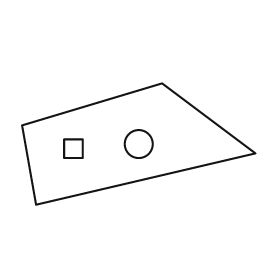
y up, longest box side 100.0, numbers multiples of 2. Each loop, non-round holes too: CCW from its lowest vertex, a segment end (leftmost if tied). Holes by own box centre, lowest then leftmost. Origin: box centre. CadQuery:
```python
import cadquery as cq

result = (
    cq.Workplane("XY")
    .moveTo(-44.0, -26.0)
    .lineTo(50.0, -4.0)
    .lineTo(10.0, 26.0)
    .lineTo(-50.0, 8.0)
    .close()
    .moveTo(-32.0, -6.0)
    .lineTo(-24.0, -6.0)
    .lineTo(-24.0, 2.0)
    .lineTo(-32.0, 2.0)
    .close()
    .moveTo(0.0, 0.0)
    .circle(6.0)
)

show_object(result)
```